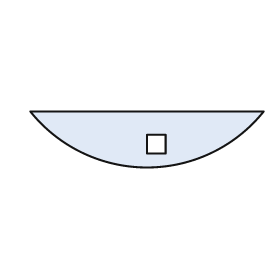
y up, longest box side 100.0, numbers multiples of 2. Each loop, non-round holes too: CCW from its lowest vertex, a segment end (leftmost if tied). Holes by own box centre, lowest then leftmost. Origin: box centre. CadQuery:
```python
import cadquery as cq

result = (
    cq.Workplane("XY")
    .moveTo(-50.0, 12.0)
    .threePointArc((0.0, -12.0), (50.0, 12.0))
    .close()
    .moveTo(0.0, -6.0)
    .lineTo(8.0, -6.0)
    .lineTo(8.0, 2.0)
    .lineTo(0.0, 2.0)
    .close()
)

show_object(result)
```